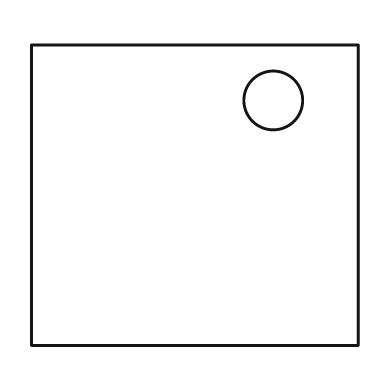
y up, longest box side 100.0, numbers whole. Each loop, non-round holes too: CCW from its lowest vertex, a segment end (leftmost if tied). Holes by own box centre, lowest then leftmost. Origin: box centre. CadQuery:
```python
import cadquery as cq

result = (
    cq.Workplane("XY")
    .moveTo(-50.0, -46.0)
    .lineTo(50.0, -46.0)
    .lineTo(50.0, 46.0)
    .lineTo(-50.0, 46.0)
    .close()
    .moveTo(24.0, 29.0)
    .circle(9.0)
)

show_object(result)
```